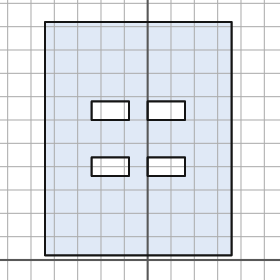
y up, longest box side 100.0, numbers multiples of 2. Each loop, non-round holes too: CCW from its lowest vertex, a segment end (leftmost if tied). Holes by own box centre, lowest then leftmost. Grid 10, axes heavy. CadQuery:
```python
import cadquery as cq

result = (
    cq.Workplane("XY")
    .moveTo(-44.0, 2.0)
    .lineTo(36.0, 2.0)
    .lineTo(36.0, 102.0)
    .lineTo(-44.0, 102.0)
    .close()
    .moveTo(-24.0, 36.0)
    .lineTo(-8.0, 36.0)
    .lineTo(-8.0, 44.0)
    .lineTo(-24.0, 44.0)
    .close()
    .moveTo(0.0, 36.0)
    .lineTo(16.0, 36.0)
    .lineTo(16.0, 44.0)
    .lineTo(0.0, 44.0)
    .close()
    .moveTo(-24.0, 60.0)
    .lineTo(-8.0, 60.0)
    .lineTo(-8.0, 68.0)
    .lineTo(-24.0, 68.0)
    .close()
    .moveTo(0.0, 60.0)
    .lineTo(16.0, 60.0)
    .lineTo(16.0, 68.0)
    .lineTo(0.0, 68.0)
    .close()
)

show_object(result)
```